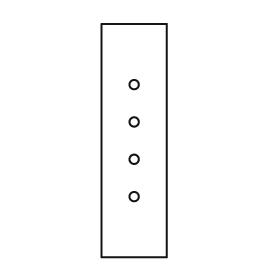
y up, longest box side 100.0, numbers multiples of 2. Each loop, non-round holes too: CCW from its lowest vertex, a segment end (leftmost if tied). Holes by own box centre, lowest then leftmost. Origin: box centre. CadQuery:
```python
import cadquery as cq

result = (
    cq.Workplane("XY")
    .moveTo(-14.0, -50.0)
    .lineTo(14.0, -50.0)
    .lineTo(14.0, 50.0)
    .lineTo(-14.0, 50.0)
    .close()
    .moveTo(0.0, -24.0)
    .circle(2.0)
    .moveTo(0.0, -8.0)
    .circle(2.0)
    .moveTo(0.0, 8.0)
    .circle(2.0)
    .moveTo(0.0, 24.0)
    .circle(2.0)
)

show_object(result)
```